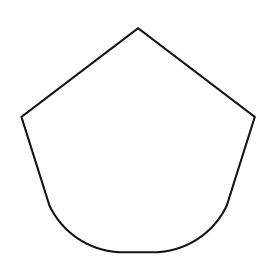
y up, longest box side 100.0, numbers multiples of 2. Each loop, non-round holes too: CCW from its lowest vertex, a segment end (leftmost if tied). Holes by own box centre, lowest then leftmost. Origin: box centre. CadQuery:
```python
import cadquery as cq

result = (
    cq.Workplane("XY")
    .moveTo(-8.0, -48.0)
    .lineTo(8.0, -48.0)
    .threePointArc((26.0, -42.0), (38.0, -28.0))
    .lineTo(50.0, 10.0)
    .lineTo(0.0, 48.0)
    .lineTo(-50.0, 10.0)
    .lineTo(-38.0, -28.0)
    .threePointArc((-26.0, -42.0), (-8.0, -48.0))
    .close()
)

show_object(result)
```